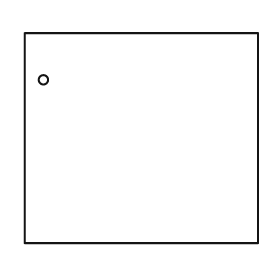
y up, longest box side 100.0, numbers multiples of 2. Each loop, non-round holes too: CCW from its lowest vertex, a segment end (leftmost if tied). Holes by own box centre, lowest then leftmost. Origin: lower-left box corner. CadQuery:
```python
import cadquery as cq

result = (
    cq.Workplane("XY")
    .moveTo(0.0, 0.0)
    .lineTo(100.0, 0.0)
    .lineTo(100.0, 90.0)
    .lineTo(0.0, 90.0)
    .close()
    .moveTo(8.0, 70.0)
    .circle(2.0)
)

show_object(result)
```